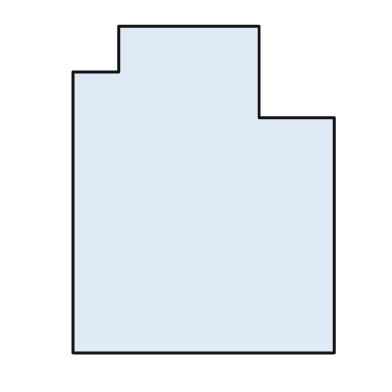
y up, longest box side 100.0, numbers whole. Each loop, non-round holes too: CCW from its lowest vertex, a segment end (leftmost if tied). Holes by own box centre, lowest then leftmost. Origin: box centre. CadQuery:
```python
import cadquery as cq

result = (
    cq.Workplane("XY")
    .moveTo(-40.0, -50.0)
    .lineTo(40.0, -50.0)
    .lineTo(40.0, 22.0)
    .lineTo(17.0, 22.0)
    .lineTo(17.0, 50.0)
    .lineTo(-26.0, 50.0)
    .lineTo(-26.0, 36.0)
    .lineTo(-40.0, 36.0)
    .close()
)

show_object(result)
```